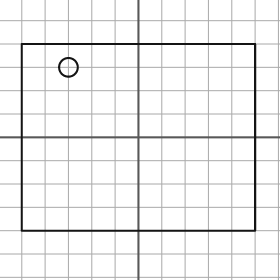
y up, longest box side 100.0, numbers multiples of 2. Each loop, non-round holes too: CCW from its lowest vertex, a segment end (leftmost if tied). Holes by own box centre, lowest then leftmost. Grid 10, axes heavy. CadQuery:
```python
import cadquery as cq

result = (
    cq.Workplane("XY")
    .moveTo(-50.0, -40.0)
    .lineTo(50.0, -40.0)
    .lineTo(50.0, 40.0)
    .lineTo(-50.0, 40.0)
    .close()
    .moveTo(-30.0, 30.0)
    .circle(4.0)
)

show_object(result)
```